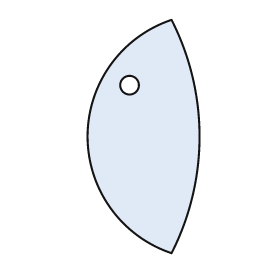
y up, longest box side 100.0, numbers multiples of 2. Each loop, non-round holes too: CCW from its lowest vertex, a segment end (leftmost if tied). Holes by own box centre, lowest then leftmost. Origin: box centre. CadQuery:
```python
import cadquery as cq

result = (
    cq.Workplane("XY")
    .moveTo(12.0, -50.0)
    .threePointArc((24.0, 0.0), (12.0, 50.0))
    .threePointArc((-24.0, 0.0), (12.0, -50.0))
    .close()
    .moveTo(-6.0, 22.0)
    .circle(4.0)
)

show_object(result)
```